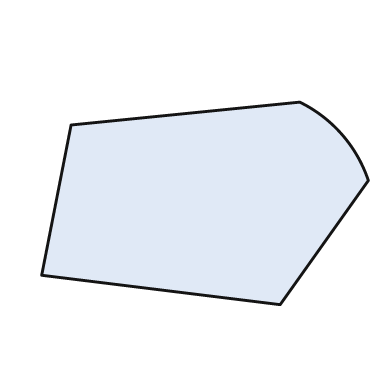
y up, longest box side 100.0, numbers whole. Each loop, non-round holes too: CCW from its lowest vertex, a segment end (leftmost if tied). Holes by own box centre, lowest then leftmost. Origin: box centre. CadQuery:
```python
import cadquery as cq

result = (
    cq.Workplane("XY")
    .moveTo(23.0, -31.0)
    .lineTo(50.0, 7.0)
    .threePointArc((42.0, 21.0), (29.0, 31.0))
    .lineTo(-41.0, 24.0)
    .lineTo(-50.0, -22.0)
    .close()
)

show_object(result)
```